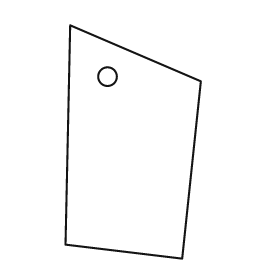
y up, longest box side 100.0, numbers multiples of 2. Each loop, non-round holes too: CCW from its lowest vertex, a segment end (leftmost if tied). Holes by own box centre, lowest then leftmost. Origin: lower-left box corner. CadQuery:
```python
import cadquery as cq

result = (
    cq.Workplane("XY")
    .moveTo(50.0, 0.0)
    .lineTo(58.0, 76.0)
    .lineTo(2.0, 100.0)
    .lineTo(0.0, 6.0)
    .close()
    .moveTo(18.0, 78.0)
    .circle(4.0)
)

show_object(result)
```